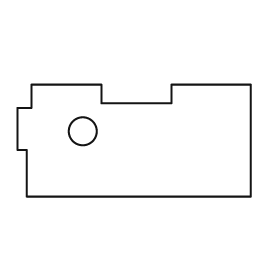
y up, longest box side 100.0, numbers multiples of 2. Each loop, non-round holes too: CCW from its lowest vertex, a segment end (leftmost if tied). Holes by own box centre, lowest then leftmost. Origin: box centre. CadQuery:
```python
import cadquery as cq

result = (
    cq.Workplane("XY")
    .moveTo(-46.0, -24.0)
    .lineTo(50.0, -24.0)
    .lineTo(50.0, 24.0)
    .lineTo(16.0, 24.0)
    .lineTo(16.0, 16.0)
    .lineTo(-14.0, 16.0)
    .lineTo(-14.0, 24.0)
    .lineTo(-44.0, 24.0)
    .lineTo(-44.0, 14.0)
    .lineTo(-50.0, 14.0)
    .lineTo(-50.0, -4.0)
    .lineTo(-46.0, -4.0)
    .close()
    .moveTo(-22.0, 4.0)
    .circle(6.0)
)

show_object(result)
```